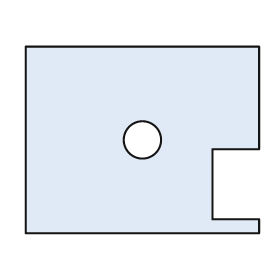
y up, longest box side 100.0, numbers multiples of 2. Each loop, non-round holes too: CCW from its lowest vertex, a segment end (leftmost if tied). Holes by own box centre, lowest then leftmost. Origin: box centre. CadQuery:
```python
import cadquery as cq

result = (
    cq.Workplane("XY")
    .moveTo(-50.0, -40.0)
    .lineTo(50.0, -40.0)
    .lineTo(50.0, -34.0)
    .lineTo(30.0, -34.0)
    .lineTo(30.0, -4.0)
    .lineTo(50.0, -4.0)
    .lineTo(50.0, 40.0)
    .lineTo(-50.0, 40.0)
    .close()
    .moveTo(0.0, 0.0)
    .circle(8.0)
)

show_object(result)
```